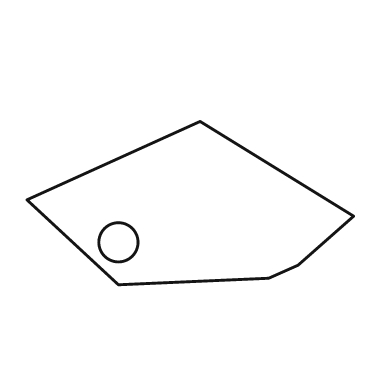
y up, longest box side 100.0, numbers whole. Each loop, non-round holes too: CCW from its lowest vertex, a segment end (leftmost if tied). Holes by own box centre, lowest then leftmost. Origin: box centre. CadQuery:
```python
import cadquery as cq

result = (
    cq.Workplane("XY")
    .moveTo(-22.0, -25.0)
    .lineTo(24.0, -23.0)
    .lineTo(33.0, -19.0)
    .lineTo(50.0, -4.0)
    .lineTo(3.0, 25.0)
    .lineTo(-50.0, 1.0)
    .close()
    .moveTo(-22.0, -12.0)
    .circle(6.0)
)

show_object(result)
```